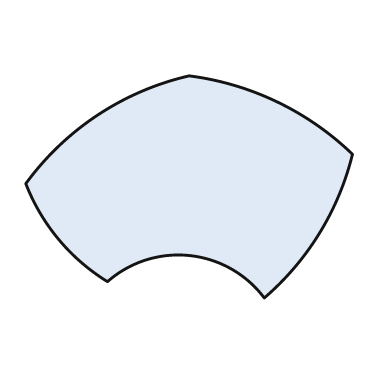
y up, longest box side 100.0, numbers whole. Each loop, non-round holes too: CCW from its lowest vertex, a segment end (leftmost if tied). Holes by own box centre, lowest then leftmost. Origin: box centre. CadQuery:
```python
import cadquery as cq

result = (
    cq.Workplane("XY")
    .moveTo(23.0, -34.0)
    .threePointArc((40.0, -14.0), (50.0, 10.0))
    .threePointArc((27.0, 26.0), (0.0, 34.0))
    .threePointArc((-28.0, 22.0), (-50.0, 1.0))
    .threePointArc((-40.0, -16.0), (-25.0, -29.0))
    .threePointArc((0.0, -21.0), (23.0, -34.0))
    .close()
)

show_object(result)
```